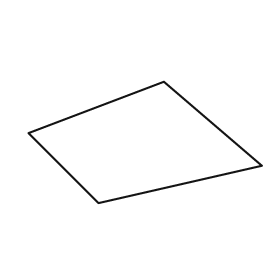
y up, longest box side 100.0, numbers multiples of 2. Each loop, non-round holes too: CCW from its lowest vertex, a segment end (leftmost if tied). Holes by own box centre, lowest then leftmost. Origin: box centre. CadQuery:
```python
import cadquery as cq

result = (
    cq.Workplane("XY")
    .moveTo(-20.0, -26.0)
    .lineTo(50.0, -10.0)
    .lineTo(8.0, 26.0)
    .lineTo(-50.0, 4.0)
    .close()
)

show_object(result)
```